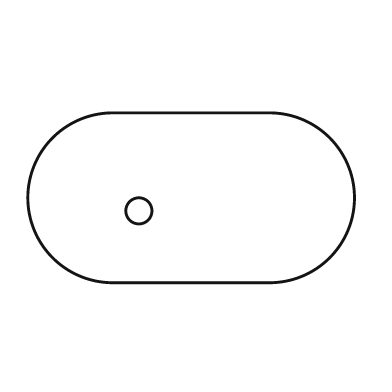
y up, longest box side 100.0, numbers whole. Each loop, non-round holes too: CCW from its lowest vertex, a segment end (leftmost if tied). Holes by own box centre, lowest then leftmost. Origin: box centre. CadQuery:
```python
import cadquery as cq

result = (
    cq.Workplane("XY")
    .moveTo(-24.0, -26.0)
    .lineTo(24.0, -26.0)
    .threePointArc((50.0, 0.0), (24.0, 26.0))
    .lineTo(-24.0, 26.0)
    .threePointArc((-50.0, 0.0), (-24.0, -26.0))
    .close()
    .moveTo(-16.0, -4.0)
    .circle(4.0)
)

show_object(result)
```